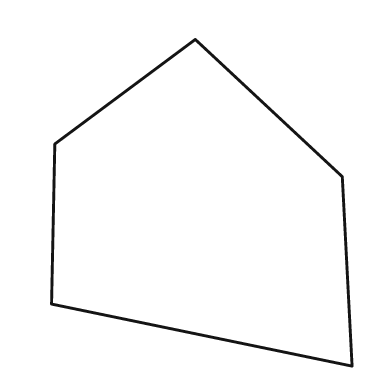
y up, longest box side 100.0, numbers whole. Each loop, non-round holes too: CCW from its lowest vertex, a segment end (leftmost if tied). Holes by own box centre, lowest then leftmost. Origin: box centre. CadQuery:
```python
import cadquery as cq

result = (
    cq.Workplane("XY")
    .moveTo(46.0, -50.0)
    .lineTo(43.0, 8.0)
    .lineTo(-2.0, 50.0)
    .lineTo(-45.0, 18.0)
    .lineTo(-46.0, -31.0)
    .close()
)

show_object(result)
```